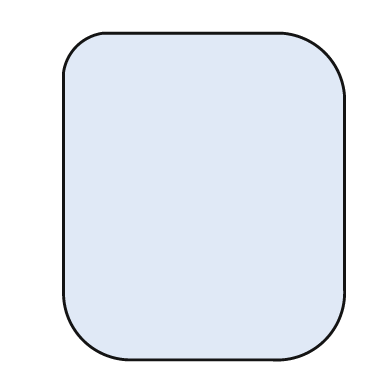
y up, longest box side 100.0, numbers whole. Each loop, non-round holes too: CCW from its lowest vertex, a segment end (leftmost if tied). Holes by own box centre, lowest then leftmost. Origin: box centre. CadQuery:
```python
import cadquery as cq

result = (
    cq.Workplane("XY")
    .moveTo(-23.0, -50.0)
    .lineTo(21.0, -50.0)
    .threePointArc((37.0, -44.0), (43.0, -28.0))
    .lineTo(43.0, 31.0)
    .threePointArc((37.0, 44.0), (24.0, 50.0))
    .lineTo(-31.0, 50.0)
    .threePointArc((-39.0, 46.0), (-43.0, 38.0))
    .lineTo(-43.0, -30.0)
    .threePointArc((-37.0, -44.0), (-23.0, -50.0))
    .close()
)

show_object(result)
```